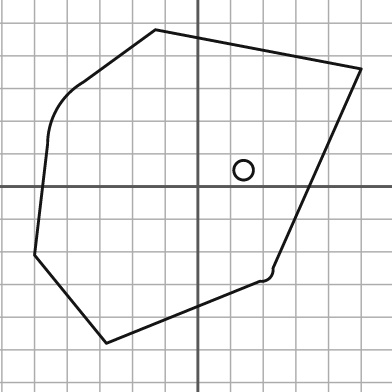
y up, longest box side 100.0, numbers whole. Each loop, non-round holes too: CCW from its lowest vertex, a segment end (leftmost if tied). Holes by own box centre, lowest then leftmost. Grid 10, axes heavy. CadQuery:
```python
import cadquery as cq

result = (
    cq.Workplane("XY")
    .moveTo(-28.0, -48.0)
    .lineTo(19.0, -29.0)
    .threePointArc((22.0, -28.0), (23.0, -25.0))
    .lineTo(50.0, 36.0)
    .lineTo(-13.0, 48.0)
    .lineTo(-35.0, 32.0)
    .threePointArc((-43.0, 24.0), (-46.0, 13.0))
    .lineTo(-50.0, -21.0)
    .close()
    .moveTo(14.0, 5.0)
    .circle(3.0)
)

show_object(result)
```